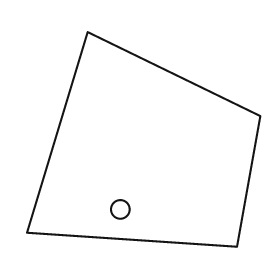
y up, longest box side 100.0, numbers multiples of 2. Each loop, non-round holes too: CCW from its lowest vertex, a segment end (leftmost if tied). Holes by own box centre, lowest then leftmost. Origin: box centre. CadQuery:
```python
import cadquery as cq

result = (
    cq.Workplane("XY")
    .moveTo(40.0, -46.0)
    .lineTo(50.0, 10.0)
    .lineTo(-24.0, 46.0)
    .lineTo(-50.0, -40.0)
    .close()
    .moveTo(-10.0, -30.0)
    .circle(4.0)
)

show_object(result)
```